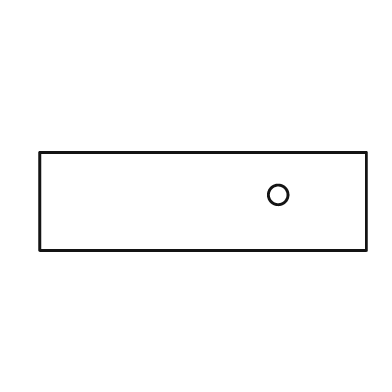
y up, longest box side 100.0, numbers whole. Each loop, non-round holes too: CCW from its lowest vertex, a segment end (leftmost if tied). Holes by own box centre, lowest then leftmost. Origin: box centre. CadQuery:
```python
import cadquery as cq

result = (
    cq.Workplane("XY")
    .moveTo(-50.0, -15.0)
    .lineTo(50.0, -15.0)
    .lineTo(50.0, 15.0)
    .lineTo(-50.0, 15.0)
    .close()
    .moveTo(23.0, 2.0)
    .circle(3.0)
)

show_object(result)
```